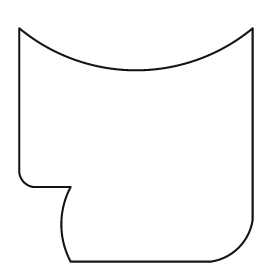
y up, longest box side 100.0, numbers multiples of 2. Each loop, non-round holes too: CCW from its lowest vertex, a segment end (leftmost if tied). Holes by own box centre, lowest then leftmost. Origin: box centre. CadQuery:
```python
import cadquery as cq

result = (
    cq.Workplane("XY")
    .moveTo(-28.0, -50.0)
    .lineTo(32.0, -50.0)
    .threePointArc((44.0, -44.0), (50.0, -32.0))
    .lineTo(50.0, 50.0)
    .threePointArc((0.0, 32.0), (-50.0, 50.0))
    .lineTo(-50.0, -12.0)
    .threePointArc((-48.0, -16.0), (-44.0, -18.0))
    .lineTo(-28.0, -18.0)
    .threePointArc((-32.0, -34.0), (-28.0, -50.0))
    .close()
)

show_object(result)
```